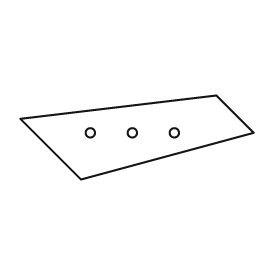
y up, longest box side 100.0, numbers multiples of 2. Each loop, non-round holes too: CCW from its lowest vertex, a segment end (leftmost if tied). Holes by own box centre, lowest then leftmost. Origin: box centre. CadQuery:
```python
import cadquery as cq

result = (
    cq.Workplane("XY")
    .moveTo(-24.0, -18.0)
    .lineTo(50.0, 2.0)
    .lineTo(34.0, 18.0)
    .lineTo(-50.0, 8.0)
    .close()
    .moveTo(-20.0, 2.0)
    .circle(2.0)
    .moveTo(-2.0, 2.0)
    .circle(2.0)
    .moveTo(16.0, 2.0)
    .circle(2.0)
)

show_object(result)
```